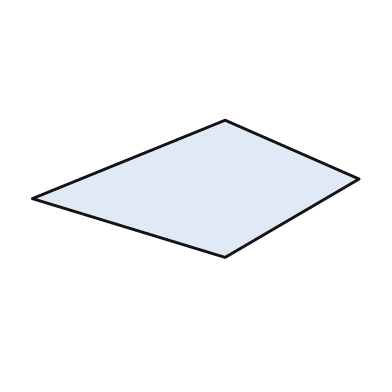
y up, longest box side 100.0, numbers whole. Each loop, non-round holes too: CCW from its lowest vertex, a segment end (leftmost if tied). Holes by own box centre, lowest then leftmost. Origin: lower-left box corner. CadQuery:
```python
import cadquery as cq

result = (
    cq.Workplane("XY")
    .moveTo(59.0, 0.0)
    .lineTo(100.0, 24.0)
    .lineTo(59.0, 42.0)
    .lineTo(0.0, 18.0)
    .close()
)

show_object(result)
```